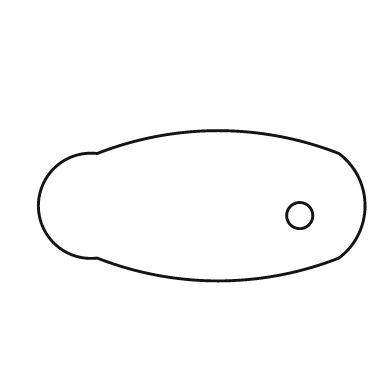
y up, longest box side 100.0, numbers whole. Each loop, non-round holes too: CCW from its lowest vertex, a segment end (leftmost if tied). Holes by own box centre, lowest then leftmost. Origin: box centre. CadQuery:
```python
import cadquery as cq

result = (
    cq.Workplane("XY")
    .moveTo(-32.0, -16.0)
    .threePointArc((5.0, -23.0), (42.0, -16.0))
    .threePointArc((50.0, 0.0), (42.0, 16.0))
    .threePointArc((5.0, 23.0), (-32.0, 16.0))
    .threePointArc((-50.0, 0.0), (-32.0, -16.0))
    .close()
    .moveTo(30.0, -3.0)
    .circle(4.0)
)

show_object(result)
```